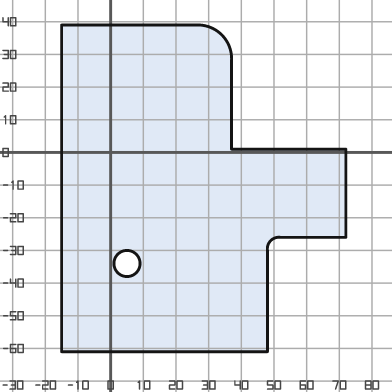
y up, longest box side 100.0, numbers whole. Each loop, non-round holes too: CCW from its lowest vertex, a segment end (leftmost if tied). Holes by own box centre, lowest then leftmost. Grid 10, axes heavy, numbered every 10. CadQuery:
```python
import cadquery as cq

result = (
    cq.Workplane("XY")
    .moveTo(-15.0, -61.0)
    .lineTo(48.0, -61.0)
    .lineTo(48.0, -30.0)
    .threePointArc((49.0, -27.0), (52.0, -26.0))
    .lineTo(72.0, -26.0)
    .lineTo(72.0, 1.0)
    .lineTo(37.0, 1.0)
    .lineTo(37.0, 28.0)
    .threePointArc((34.0, 36.0), (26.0, 39.0))
    .lineTo(-15.0, 39.0)
    .close()
    .moveTo(5.0, -34.0)
    .circle(4.0)
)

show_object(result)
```